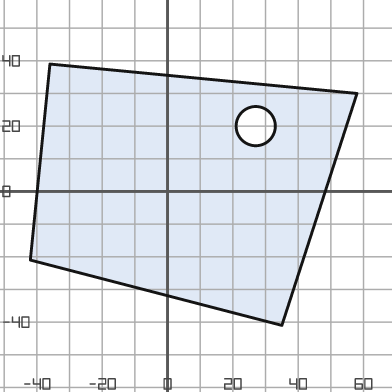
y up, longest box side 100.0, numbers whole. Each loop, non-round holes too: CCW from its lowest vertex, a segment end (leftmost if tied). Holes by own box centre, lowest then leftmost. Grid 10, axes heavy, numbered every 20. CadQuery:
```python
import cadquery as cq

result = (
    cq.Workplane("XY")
    .moveTo(35.0, -41.0)
    .lineTo(58.0, 30.0)
    .lineTo(-36.0, 39.0)
    .lineTo(-42.0, -21.0)
    .close()
    .moveTo(27.0, 20.0)
    .circle(6.0)
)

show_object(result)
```